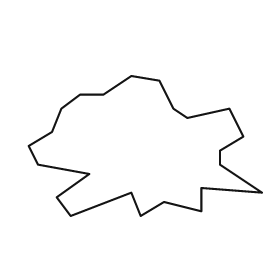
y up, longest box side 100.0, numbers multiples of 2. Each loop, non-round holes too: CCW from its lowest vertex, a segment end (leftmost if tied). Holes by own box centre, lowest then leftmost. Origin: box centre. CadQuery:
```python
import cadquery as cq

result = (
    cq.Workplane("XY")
    .moveTo(-32.0, -30.0)
    .lineTo(-6.0, -20.0)
    .lineTo(-2.0, -30.0)
    .lineTo(8.0, -24.0)
    .lineTo(24.0, -28.0)
    .lineTo(24.0, -18.0)
    .lineTo(50.0, -20.0)
    .lineTo(32.0, -8.0)
    .lineTo(32.0, -2.0)
    .lineTo(42.0, 4.0)
    .lineTo(36.0, 16.0)
    .lineTo(18.0, 12.0)
    .lineTo(12.0, 16.0)
    .lineTo(6.0, 28.0)
    .lineTo(-6.0, 30.0)
    .lineTo(-18.0, 22.0)
    .lineTo(-28.0, 22.0)
    .lineTo(-36.0, 16.0)
    .lineTo(-40.0, 6.0)
    .lineTo(-50.0, 0.0)
    .lineTo(-46.0, -8.0)
    .lineTo(-24.0, -12.0)
    .lineTo(-38.0, -22.0)
    .close()
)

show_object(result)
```